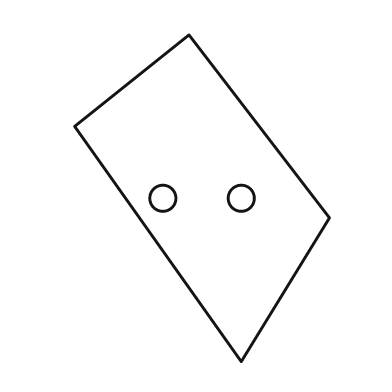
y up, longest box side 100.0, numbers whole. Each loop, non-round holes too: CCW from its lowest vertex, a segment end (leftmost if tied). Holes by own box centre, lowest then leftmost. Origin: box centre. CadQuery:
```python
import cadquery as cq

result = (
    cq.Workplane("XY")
    .moveTo(12.0, -50.0)
    .lineTo(39.0, -6.0)
    .lineTo(-4.0, 50.0)
    .lineTo(-39.0, 22.0)
    .close()
    .moveTo(-12.0, 0.0)
    .circle(4.0)
    .moveTo(12.0, 0.0)
    .circle(4.0)
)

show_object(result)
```